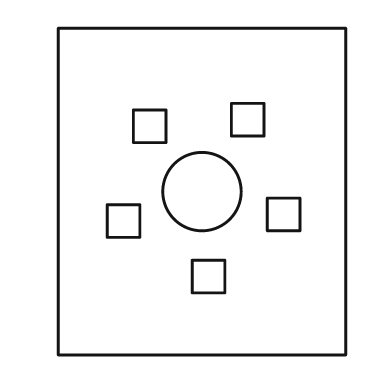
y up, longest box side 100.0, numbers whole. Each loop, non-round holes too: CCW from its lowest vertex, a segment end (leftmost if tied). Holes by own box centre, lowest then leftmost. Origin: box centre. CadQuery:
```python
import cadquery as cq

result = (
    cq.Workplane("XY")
    .moveTo(-44.0, -50.0)
    .lineTo(44.0, -50.0)
    .lineTo(44.0, 50.0)
    .lineTo(-44.0, 50.0)
    .close()
    .moveTo(-3.0, -31.0)
    .lineTo(7.0, -31.0)
    .lineTo(7.0, -21.0)
    .lineTo(-3.0, -21.0)
    .close()
    .moveTo(-29.0, -14.0)
    .lineTo(-19.0, -14.0)
    .lineTo(-19.0, -4.0)
    .lineTo(-29.0, -4.0)
    .close()
    .moveTo(20.0, -12.0)
    .lineTo(30.0, -12.0)
    .lineTo(30.0, -2.0)
    .lineTo(20.0, -2.0)
    .close()
    .moveTo(0.0, 0.0)
    .circle(12.0)
    .moveTo(-21.0, 15.0)
    .lineTo(-11.0, 15.0)
    .lineTo(-11.0, 25.0)
    .lineTo(-21.0, 25.0)
    .close()
    .moveTo(9.0, 17.0)
    .lineTo(19.0, 17.0)
    .lineTo(19.0, 27.0)
    .lineTo(9.0, 27.0)
    .close()
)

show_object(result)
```